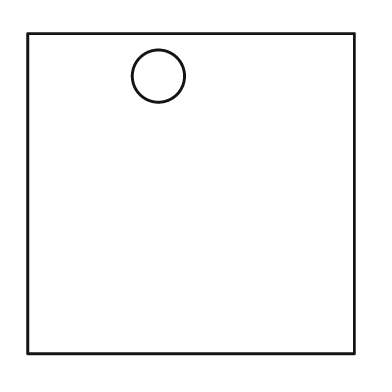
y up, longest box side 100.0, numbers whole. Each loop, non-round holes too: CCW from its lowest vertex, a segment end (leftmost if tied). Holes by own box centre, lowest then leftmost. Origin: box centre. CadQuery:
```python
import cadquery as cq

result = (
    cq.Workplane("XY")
    .moveTo(-50.0, -49.0)
    .lineTo(50.0, -49.0)
    .lineTo(50.0, 49.0)
    .lineTo(-50.0, 49.0)
    .close()
    .moveTo(-10.0, 36.0)
    .circle(8.0)
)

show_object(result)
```